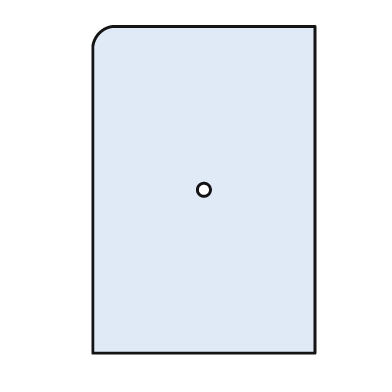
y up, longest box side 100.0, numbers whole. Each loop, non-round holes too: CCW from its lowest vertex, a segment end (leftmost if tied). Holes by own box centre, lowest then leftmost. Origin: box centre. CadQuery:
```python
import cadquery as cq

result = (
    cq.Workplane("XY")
    .moveTo(-34.0, -50.0)
    .lineTo(34.0, -50.0)
    .lineTo(34.0, 50.0)
    .lineTo(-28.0, 50.0)
    .threePointArc((-32.0, 48.0), (-34.0, 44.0))
    .close()
    .moveTo(0.0, 0.0)
    .circle(2.0)
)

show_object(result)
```